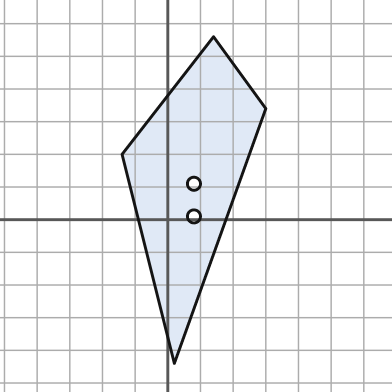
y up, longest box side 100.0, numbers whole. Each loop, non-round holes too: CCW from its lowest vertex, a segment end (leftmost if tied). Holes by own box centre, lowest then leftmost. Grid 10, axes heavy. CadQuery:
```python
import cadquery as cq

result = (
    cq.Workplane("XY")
    .moveTo(2.0, -44.0)
    .lineTo(30.0, 34.0)
    .lineTo(14.0, 56.0)
    .lineTo(-14.0, 20.0)
    .close()
    .moveTo(8.0, 1.0)
    .circle(2.0)
    .moveTo(8.0, 11.0)
    .circle(2.0)
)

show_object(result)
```